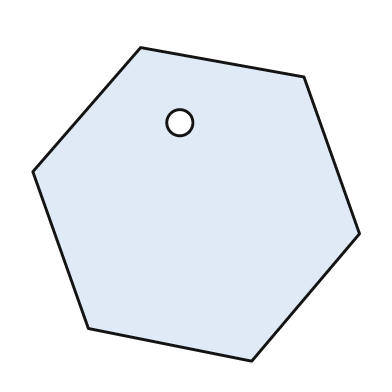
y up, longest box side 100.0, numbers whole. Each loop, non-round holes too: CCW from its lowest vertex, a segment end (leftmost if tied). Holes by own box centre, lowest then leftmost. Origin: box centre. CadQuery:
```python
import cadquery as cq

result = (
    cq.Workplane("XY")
    .moveTo(17.0, -48.0)
    .lineTo(50.0, -9.0)
    .lineTo(33.0, 39.0)
    .lineTo(-17.0, 48.0)
    .lineTo(-50.0, 10.0)
    .lineTo(-33.0, -38.0)
    .close()
    .moveTo(-5.0, 25.0)
    .circle(4.0)
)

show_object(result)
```